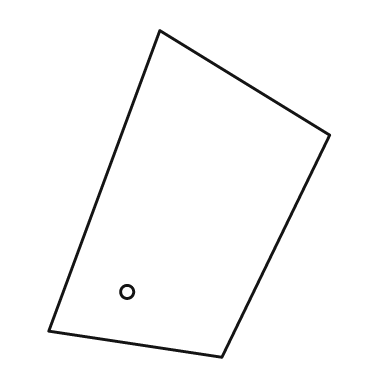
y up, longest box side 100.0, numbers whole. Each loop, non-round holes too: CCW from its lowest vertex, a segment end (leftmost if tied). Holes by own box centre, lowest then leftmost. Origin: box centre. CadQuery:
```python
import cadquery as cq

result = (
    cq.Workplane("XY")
    .moveTo(10.0, -50.0)
    .lineTo(43.0, 18.0)
    .lineTo(-9.0, 50.0)
    .lineTo(-43.0, -42.0)
    .close()
    .moveTo(-19.0, -30.0)
    .circle(2.0)
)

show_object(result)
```